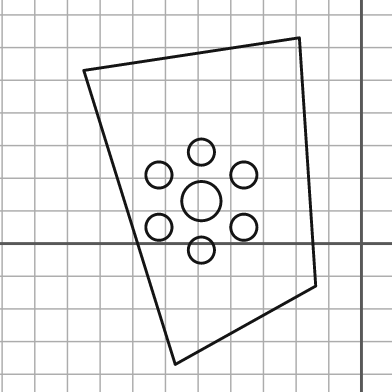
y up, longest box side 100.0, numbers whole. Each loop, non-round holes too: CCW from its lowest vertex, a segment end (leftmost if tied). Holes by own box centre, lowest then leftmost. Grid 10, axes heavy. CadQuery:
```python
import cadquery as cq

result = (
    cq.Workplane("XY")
    .moveTo(-57.0, -37.0)
    .lineTo(-14.0, -13.0)
    .lineTo(-19.0, 63.0)
    .lineTo(-85.0, 53.0)
    .close()
    .moveTo(-49.0, -2.0)
    .circle(4.0)
    .moveTo(-62.0, 5.0)
    .circle(4.0)
    .moveTo(-36.0, 5.0)
    .circle(4.0)
    .moveTo(-49.0, 13.0)
    .circle(6.0)
    .moveTo(-62.0, 21.0)
    .circle(4.0)
    .moveTo(-36.0, 21.0)
    .circle(4.0)
    .moveTo(-49.0, 28.0)
    .circle(4.0)
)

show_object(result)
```